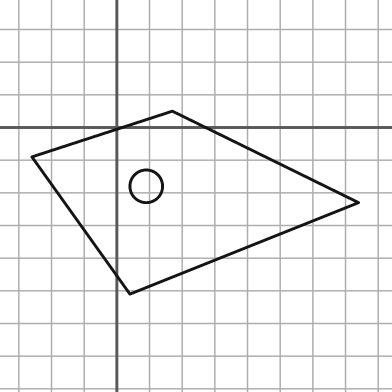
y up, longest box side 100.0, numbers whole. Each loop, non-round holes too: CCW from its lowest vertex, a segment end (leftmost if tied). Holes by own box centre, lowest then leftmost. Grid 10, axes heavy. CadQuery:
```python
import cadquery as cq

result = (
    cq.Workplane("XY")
    .moveTo(4.0, -51.0)
    .lineTo(74.0, -23.0)
    .lineTo(17.0, 5.0)
    .lineTo(-26.0, -9.0)
    .close()
    .moveTo(9.0, -18.0)
    .circle(5.0)
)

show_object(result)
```